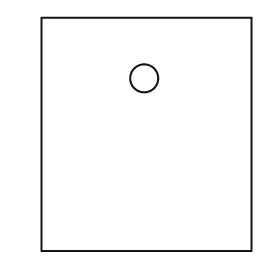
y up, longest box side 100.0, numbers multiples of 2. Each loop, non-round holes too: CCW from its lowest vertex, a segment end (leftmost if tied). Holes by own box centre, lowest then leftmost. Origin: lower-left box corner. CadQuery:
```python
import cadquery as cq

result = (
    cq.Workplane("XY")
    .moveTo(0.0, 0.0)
    .lineTo(90.0, 0.0)
    .lineTo(90.0, 100.0)
    .lineTo(0.0, 100.0)
    .close()
    .moveTo(44.0, 74.0)
    .circle(6.0)
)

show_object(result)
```